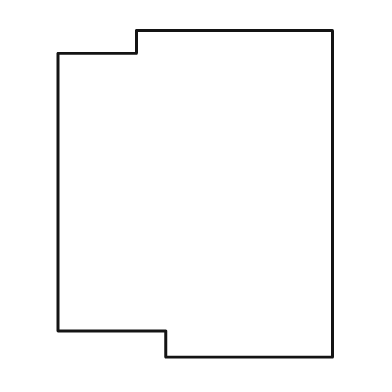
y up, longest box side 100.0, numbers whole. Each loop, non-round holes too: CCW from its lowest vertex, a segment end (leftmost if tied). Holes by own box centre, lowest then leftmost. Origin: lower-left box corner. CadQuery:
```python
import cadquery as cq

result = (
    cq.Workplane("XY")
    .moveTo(33.0, 0.0)
    .lineTo(84.0, 0.0)
    .lineTo(84.0, 100.0)
    .lineTo(24.0, 100.0)
    .lineTo(24.0, 93.0)
    .lineTo(0.0, 93.0)
    .lineTo(0.0, 8.0)
    .lineTo(33.0, 8.0)
    .close()
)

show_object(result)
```